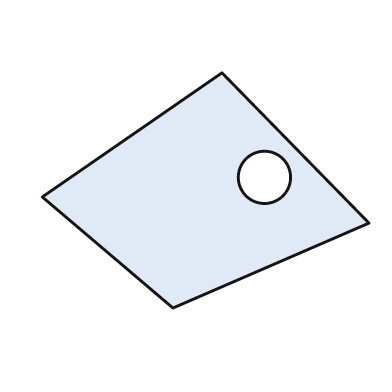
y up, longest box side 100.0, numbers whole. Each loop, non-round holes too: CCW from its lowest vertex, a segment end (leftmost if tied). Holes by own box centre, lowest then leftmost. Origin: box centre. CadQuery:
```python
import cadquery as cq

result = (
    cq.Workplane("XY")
    .moveTo(-10.0, -36.0)
    .lineTo(50.0, -10.0)
    .lineTo(5.0, 36.0)
    .lineTo(-50.0, -2.0)
    .close()
    .moveTo(18.0, 4.0)
    .circle(8.0)
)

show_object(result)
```